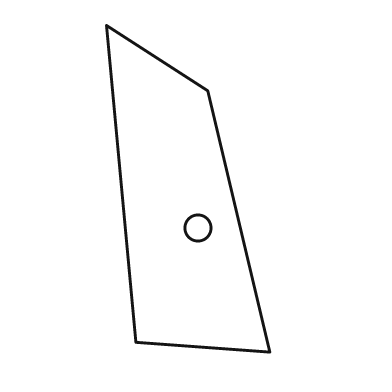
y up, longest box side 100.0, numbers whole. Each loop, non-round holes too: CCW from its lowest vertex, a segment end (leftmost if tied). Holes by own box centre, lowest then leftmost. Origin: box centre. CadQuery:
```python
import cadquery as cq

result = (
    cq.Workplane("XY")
    .moveTo(25.0, -50.0)
    .lineTo(6.0, 30.0)
    .lineTo(-25.0, 50.0)
    .lineTo(-16.0, -47.0)
    .close()
    .moveTo(3.0, -12.0)
    .circle(4.0)
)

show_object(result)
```